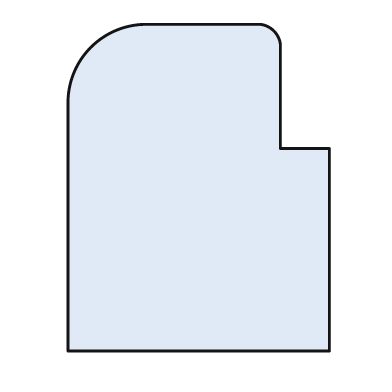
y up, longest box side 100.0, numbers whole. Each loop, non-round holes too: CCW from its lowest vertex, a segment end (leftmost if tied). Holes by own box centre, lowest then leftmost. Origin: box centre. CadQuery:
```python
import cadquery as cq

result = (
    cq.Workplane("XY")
    .moveTo(-40.0, -50.0)
    .lineTo(40.0, -50.0)
    .lineTo(40.0, 12.0)
    .lineTo(25.0, 12.0)
    .lineTo(25.0, 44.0)
    .threePointArc((23.0, 48.0), (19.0, 50.0))
    .lineTo(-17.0, 50.0)
    .threePointArc((-33.0, 43.0), (-40.0, 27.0))
    .close()
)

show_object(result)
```